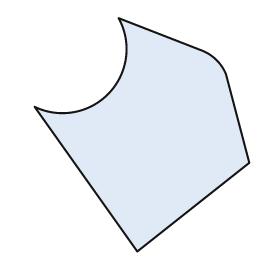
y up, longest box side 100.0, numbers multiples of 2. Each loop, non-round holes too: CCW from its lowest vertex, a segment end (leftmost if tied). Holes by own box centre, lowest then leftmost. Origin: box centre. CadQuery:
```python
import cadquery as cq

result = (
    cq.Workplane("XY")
    .moveTo(-2.0, -50.0)
    .lineTo(46.0, -12.0)
    .lineTo(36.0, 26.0)
    .threePointArc((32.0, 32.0), (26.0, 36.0))
    .lineTo(-10.0, 50.0)
    .threePointArc((-14.0, 18.0), (-46.0, 12.0))
    .close()
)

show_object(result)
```